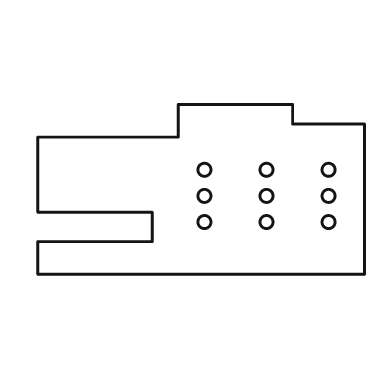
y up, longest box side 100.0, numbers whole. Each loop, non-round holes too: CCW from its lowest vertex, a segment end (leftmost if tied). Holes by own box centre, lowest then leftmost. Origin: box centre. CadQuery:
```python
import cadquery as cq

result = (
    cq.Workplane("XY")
    .moveTo(-50.0, -26.0)
    .lineTo(50.0, -26.0)
    .lineTo(50.0, 20.0)
    .lineTo(28.0, 20.0)
    .lineTo(28.0, 26.0)
    .lineTo(-7.0, 26.0)
    .lineTo(-7.0, 16.0)
    .lineTo(-50.0, 16.0)
    .lineTo(-50.0, -7.0)
    .lineTo(-15.0, -7.0)
    .lineTo(-15.0, -16.0)
    .lineTo(-50.0, -16.0)
    .close()
    .moveTo(1.0, -10.0)
    .circle(2.0)
    .moveTo(20.0, -10.0)
    .circle(2.0)
    .moveTo(39.0, -10.0)
    .circle(2.0)
    .moveTo(1.0, -2.0)
    .circle(2.0)
    .moveTo(20.0, -2.0)
    .circle(2.0)
    .moveTo(39.0, -2.0)
    .circle(2.0)
    .moveTo(1.0, 6.0)
    .circle(2.0)
    .moveTo(20.0, 6.0)
    .circle(2.0)
    .moveTo(39.0, 6.0)
    .circle(2.0)
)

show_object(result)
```